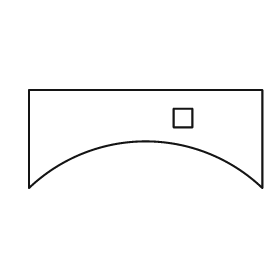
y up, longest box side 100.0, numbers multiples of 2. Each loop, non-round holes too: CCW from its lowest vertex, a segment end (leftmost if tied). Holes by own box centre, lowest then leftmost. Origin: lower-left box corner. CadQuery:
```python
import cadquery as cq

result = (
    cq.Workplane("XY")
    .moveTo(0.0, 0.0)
    .threePointArc((50.0, 20.0), (100.0, 0.0))
    .lineTo(100.0, 42.0)
    .lineTo(0.0, 42.0)
    .close()
    .moveTo(62.0, 26.0)
    .lineTo(70.0, 26.0)
    .lineTo(70.0, 34.0)
    .lineTo(62.0, 34.0)
    .close()
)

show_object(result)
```